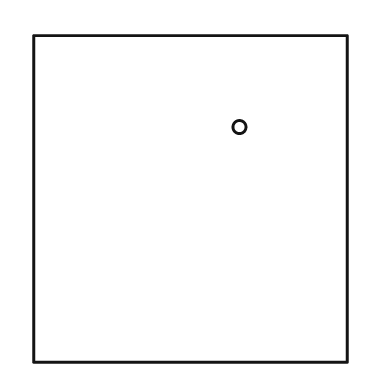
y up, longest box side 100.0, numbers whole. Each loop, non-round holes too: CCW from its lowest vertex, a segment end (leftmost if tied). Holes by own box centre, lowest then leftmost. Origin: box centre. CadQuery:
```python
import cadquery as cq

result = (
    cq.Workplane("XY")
    .moveTo(-48.0, -50.0)
    .lineTo(48.0, -50.0)
    .lineTo(48.0, 50.0)
    .lineTo(-48.0, 50.0)
    .close()
    .moveTo(15.0, 22.0)
    .circle(2.0)
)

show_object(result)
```